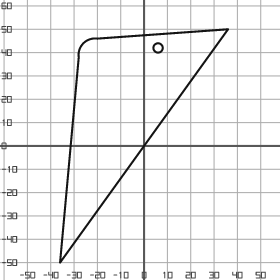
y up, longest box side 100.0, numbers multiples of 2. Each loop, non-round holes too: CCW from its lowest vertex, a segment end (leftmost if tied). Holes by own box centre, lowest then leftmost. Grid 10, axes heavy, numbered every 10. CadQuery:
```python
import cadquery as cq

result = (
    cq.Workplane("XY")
    .moveTo(-36.0, -50.0)
    .lineTo(36.0, 50.0)
    .lineTo(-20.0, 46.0)
    .threePointArc((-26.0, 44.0), (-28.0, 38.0))
    .close()
    .moveTo(6.0, 42.0)
    .circle(2.0)
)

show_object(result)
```